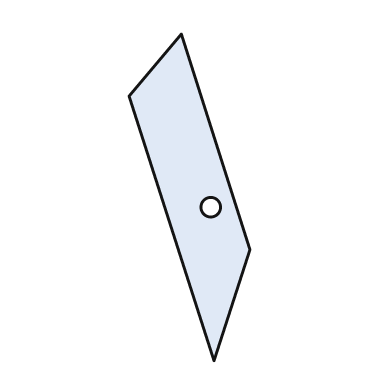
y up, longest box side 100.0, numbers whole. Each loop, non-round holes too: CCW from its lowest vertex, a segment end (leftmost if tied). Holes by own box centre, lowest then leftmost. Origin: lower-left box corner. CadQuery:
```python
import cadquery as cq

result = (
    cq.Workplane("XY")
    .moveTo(26.0, 0.0)
    .lineTo(37.0, 34.0)
    .lineTo(16.0, 100.0)
    .lineTo(0.0, 81.0)
    .close()
    .moveTo(25.0, 47.0)
    .circle(3.0)
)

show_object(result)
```